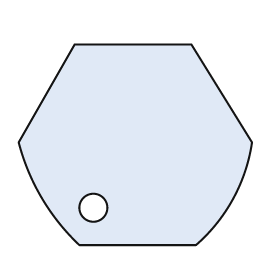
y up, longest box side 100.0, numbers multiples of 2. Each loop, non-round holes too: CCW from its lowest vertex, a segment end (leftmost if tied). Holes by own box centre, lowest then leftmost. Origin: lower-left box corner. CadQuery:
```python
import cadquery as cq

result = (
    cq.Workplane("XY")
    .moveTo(26.0, 0.0)
    .lineTo(76.0, 0.0)
    .threePointArc((92.0, 20.0), (100.0, 44.0))
    .lineTo(74.0, 86.0)
    .lineTo(24.0, 86.0)
    .lineTo(0.0, 44.0)
    .threePointArc((10.0, 20.0), (26.0, 0.0))
    .close()
    .moveTo(32.0, 16.0)
    .circle(6.0)
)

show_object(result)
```